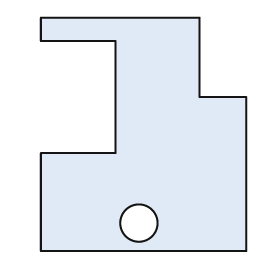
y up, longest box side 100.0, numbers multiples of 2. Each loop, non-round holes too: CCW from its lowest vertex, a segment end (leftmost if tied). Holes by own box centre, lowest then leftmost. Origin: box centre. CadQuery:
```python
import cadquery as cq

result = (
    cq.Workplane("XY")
    .moveTo(-44.0, -50.0)
    .lineTo(44.0, -50.0)
    .lineTo(44.0, 16.0)
    .lineTo(24.0, 16.0)
    .lineTo(24.0, 50.0)
    .lineTo(-44.0, 50.0)
    .lineTo(-44.0, 40.0)
    .lineTo(-12.0, 40.0)
    .lineTo(-12.0, -8.0)
    .lineTo(-44.0, -8.0)
    .close()
    .moveTo(-2.0, -38.0)
    .circle(8.0)
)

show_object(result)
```